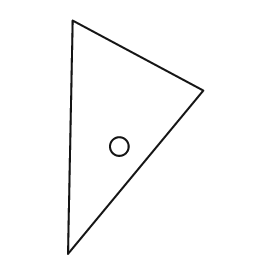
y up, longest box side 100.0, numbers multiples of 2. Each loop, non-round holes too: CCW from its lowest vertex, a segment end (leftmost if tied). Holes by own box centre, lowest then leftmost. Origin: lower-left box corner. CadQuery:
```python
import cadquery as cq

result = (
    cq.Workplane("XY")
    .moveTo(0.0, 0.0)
    .lineTo(58.0, 70.0)
    .lineTo(2.0, 100.0)
    .close()
    .moveTo(22.0, 46.0)
    .circle(4.0)
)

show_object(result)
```